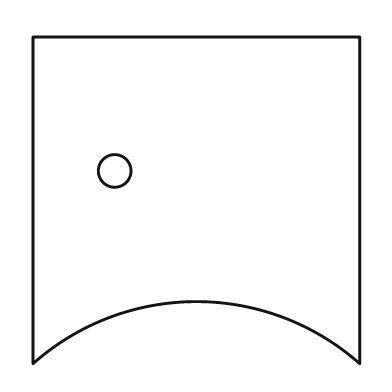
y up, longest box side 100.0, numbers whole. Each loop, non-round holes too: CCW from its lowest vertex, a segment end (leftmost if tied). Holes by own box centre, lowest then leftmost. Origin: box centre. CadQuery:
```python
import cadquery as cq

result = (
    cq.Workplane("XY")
    .moveTo(-50.0, -50.0)
    .threePointArc((0.0, -31.0), (50.0, -50.0))
    .lineTo(50.0, 50.0)
    .lineTo(-50.0, 50.0)
    .close()
    .moveTo(-25.0, 9.0)
    .circle(5.0)
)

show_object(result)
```